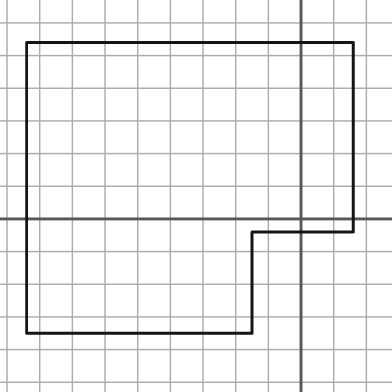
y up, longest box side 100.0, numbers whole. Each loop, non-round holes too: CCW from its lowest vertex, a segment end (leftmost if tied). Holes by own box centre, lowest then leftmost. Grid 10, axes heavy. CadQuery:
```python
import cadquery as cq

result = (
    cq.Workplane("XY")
    .moveTo(-84.0, -35.0)
    .lineTo(-15.0, -35.0)
    .lineTo(-15.0, -4.0)
    .lineTo(16.0, -4.0)
    .lineTo(16.0, 54.0)
    .lineTo(-84.0, 54.0)
    .close()
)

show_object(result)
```